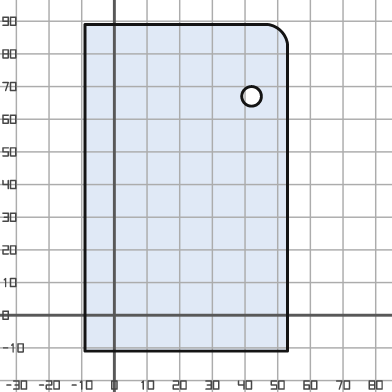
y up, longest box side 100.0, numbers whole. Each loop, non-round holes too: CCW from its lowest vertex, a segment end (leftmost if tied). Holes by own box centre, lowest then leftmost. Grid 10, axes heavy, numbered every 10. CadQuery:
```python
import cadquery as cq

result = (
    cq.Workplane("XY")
    .moveTo(-9.0, -11.0)
    .lineTo(53.0, -11.0)
    .lineTo(53.0, 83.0)
    .threePointArc((51.0, 87.0), (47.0, 89.0))
    .lineTo(-9.0, 89.0)
    .close()
    .moveTo(42.0, 67.0)
    .circle(3.0)
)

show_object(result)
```